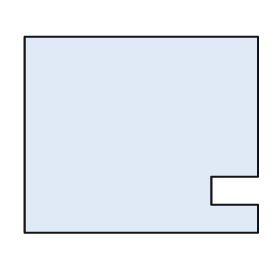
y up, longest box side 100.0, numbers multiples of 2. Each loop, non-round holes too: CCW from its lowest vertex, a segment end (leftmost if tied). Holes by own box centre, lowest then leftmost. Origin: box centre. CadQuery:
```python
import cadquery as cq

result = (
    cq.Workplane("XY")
    .moveTo(-50.0, -42.0)
    .lineTo(50.0, -42.0)
    .lineTo(50.0, -30.0)
    .lineTo(30.0, -30.0)
    .lineTo(30.0, -18.0)
    .lineTo(50.0, -18.0)
    .lineTo(50.0, 42.0)
    .lineTo(-50.0, 42.0)
    .close()
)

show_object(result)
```